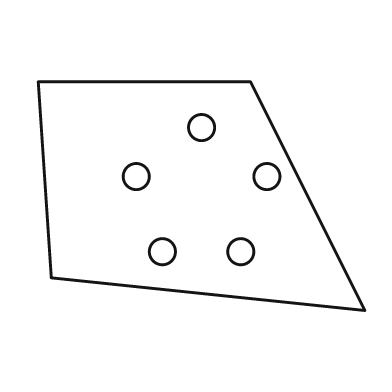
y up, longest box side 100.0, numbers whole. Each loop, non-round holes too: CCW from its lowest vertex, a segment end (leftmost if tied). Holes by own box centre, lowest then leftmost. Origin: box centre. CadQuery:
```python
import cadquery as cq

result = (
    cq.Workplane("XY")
    .moveTo(50.0, -35.0)
    .lineTo(15.0, 35.0)
    .lineTo(-50.0, 35.0)
    .lineTo(-46.0, -25.0)
    .close()
    .moveTo(-12.0, -17.0)
    .circle(4.0)
    .moveTo(12.0, -17.0)
    .circle(4.0)
    .moveTo(-20.0, 6.0)
    .circle(4.0)
    .moveTo(20.0, 6.0)
    .circle(4.0)
    .moveTo(0.0, 21.0)
    .circle(4.0)
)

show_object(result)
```